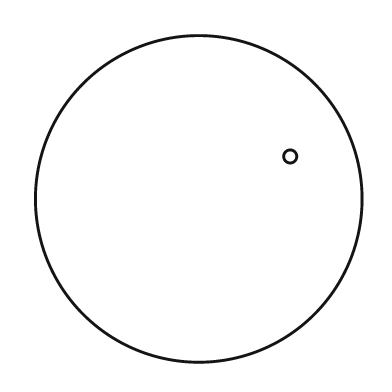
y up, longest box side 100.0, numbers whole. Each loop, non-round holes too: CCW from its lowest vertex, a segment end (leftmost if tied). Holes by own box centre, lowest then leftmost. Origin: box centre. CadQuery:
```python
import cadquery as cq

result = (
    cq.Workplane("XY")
    .moveTo(0.0, 0.0)
    .circle(50.0)
    .moveTo(28.0, 13.0)
    .circle(2.0)
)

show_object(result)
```